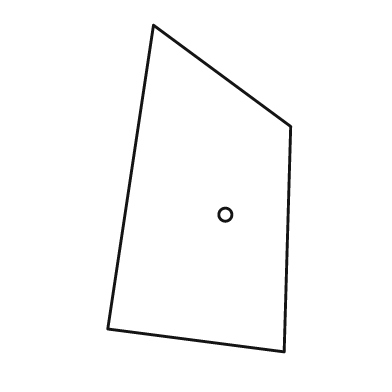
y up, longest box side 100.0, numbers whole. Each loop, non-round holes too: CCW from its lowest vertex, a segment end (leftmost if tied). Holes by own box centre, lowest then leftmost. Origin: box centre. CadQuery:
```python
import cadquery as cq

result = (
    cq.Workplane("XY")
    .moveTo(26.0, -50.0)
    .lineTo(28.0, 19.0)
    .lineTo(-14.0, 50.0)
    .lineTo(-28.0, -43.0)
    .close()
    .moveTo(8.0, -8.0)
    .circle(2.0)
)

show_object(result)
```